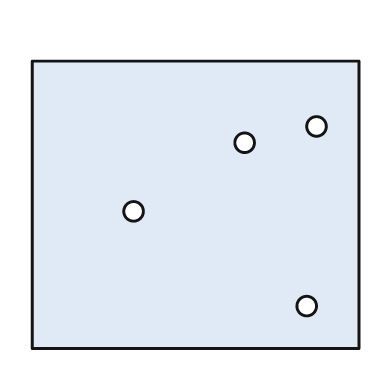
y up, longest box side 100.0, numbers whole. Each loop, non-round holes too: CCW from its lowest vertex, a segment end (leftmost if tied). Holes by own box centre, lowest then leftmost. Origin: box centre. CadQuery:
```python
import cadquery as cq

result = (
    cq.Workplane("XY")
    .moveTo(-50.0, -44.0)
    .lineTo(50.0, -44.0)
    .lineTo(50.0, 44.0)
    .lineTo(-50.0, 44.0)
    .close()
    .moveTo(34.0, -31.0)
    .circle(3.0)
    .moveTo(-19.0, -2.0)
    .circle(3.0)
    .moveTo(15.0, 19.0)
    .circle(3.0)
    .moveTo(37.0, 24.0)
    .circle(3.0)
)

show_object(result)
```